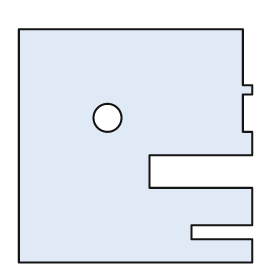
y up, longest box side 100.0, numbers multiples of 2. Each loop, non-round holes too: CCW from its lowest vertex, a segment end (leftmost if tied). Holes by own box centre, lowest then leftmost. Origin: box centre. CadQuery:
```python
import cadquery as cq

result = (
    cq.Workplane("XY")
    .moveTo(-50.0, -50.0)
    .lineTo(50.0, -50.0)
    .lineTo(50.0, -40.0)
    .lineTo(24.0, -40.0)
    .lineTo(24.0, -34.0)
    .lineTo(50.0, -34.0)
    .lineTo(50.0, -18.0)
    .lineTo(6.0, -18.0)
    .lineTo(6.0, -4.0)
    .lineTo(50.0, -4.0)
    .lineTo(50.0, 6.0)
    .lineTo(46.0, 6.0)
    .lineTo(46.0, 22.0)
    .lineTo(50.0, 22.0)
    .lineTo(50.0, 26.0)
    .lineTo(46.0, 26.0)
    .lineTo(46.0, 50.0)
    .lineTo(-50.0, 50.0)
    .close()
    .moveTo(-12.0, 12.0)
    .circle(6.0)
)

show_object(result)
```